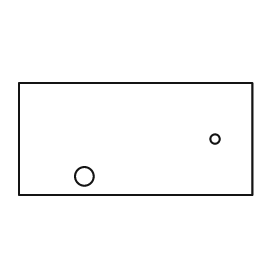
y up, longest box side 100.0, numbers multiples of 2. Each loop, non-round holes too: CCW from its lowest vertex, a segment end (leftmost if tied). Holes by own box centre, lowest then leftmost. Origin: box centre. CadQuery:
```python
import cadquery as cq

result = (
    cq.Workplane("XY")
    .moveTo(-50.0, -24.0)
    .lineTo(50.0, -24.0)
    .lineTo(50.0, 24.0)
    .lineTo(-50.0, 24.0)
    .close()
    .moveTo(-22.0, -16.0)
    .circle(4.0)
    .moveTo(34.0, 0.0)
    .circle(2.0)
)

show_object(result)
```